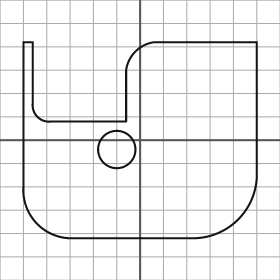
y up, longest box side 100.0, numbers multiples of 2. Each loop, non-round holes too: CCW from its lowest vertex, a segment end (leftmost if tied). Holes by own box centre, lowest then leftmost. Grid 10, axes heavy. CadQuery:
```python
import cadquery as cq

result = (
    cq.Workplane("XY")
    .moveTo(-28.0, -42.0)
    .lineTo(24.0, -42.0)
    .threePointArc((42.0, -34.0), (50.0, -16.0))
    .lineTo(50.0, 42.0)
    .lineTo(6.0, 42.0)
    .threePointArc((-2.0, 38.0), (-6.0, 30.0))
    .lineTo(-6.0, 8.0)
    .lineTo(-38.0, 8.0)
    .threePointArc((-44.0, 10.0), (-46.0, 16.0))
    .lineTo(-46.0, 42.0)
    .lineTo(-50.0, 42.0)
    .lineTo(-50.0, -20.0)
    .threePointArc((-44.0, -36.0), (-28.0, -42.0))
    .close()
    .moveTo(-10.0, -4.0)
    .circle(8.0)
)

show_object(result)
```